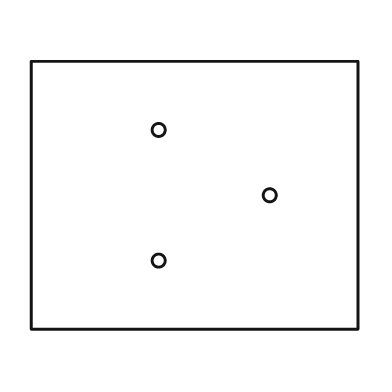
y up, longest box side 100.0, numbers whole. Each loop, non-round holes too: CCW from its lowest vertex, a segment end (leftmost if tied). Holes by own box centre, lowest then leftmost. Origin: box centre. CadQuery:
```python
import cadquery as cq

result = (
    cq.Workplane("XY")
    .moveTo(-50.0, -41.0)
    .lineTo(50.0, -41.0)
    .lineTo(50.0, 41.0)
    .lineTo(-50.0, 41.0)
    .close()
    .moveTo(-11.0, -20.0)
    .circle(2.0)
    .moveTo(23.0, 0.0)
    .circle(2.0)
    .moveTo(-11.0, 20.0)
    .circle(2.0)
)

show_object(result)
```